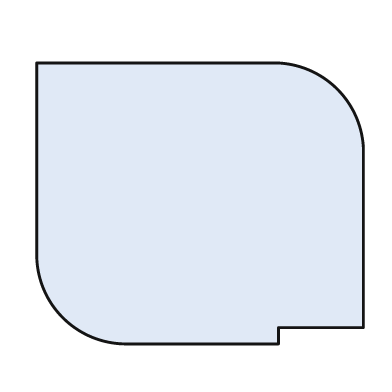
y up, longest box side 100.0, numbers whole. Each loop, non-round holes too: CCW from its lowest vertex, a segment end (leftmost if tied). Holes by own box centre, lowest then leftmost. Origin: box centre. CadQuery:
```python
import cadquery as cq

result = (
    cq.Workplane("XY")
    .moveTo(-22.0, -43.0)
    .lineTo(24.0, -43.0)
    .lineTo(24.0, -38.0)
    .lineTo(50.0, -38.0)
    .lineTo(50.0, 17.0)
    .threePointArc((42.0, 35.0), (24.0, 43.0))
    .lineTo(-50.0, 43.0)
    .lineTo(-50.0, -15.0)
    .threePointArc((-42.0, -35.0), (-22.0, -43.0))
    .close()
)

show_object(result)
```